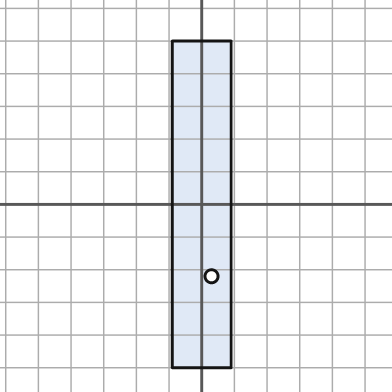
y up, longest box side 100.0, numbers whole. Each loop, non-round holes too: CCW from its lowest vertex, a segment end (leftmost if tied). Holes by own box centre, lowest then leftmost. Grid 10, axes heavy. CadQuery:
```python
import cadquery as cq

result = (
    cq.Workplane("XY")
    .moveTo(-9.0, -50.0)
    .lineTo(9.0, -50.0)
    .lineTo(9.0, 50.0)
    .lineTo(-9.0, 50.0)
    .close()
    .moveTo(3.0, -22.0)
    .circle(2.0)
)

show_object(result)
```